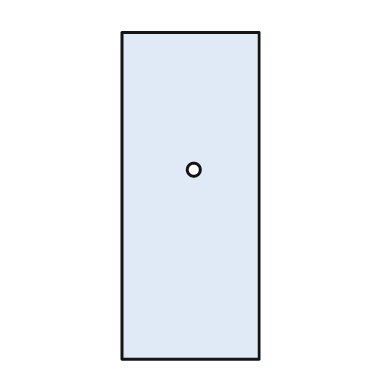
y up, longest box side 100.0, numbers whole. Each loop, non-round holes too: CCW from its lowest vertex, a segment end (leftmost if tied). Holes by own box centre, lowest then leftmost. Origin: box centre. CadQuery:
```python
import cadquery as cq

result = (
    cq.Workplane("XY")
    .moveTo(-21.0, -50.0)
    .lineTo(21.0, -50.0)
    .lineTo(21.0, 50.0)
    .lineTo(-21.0, 50.0)
    .close()
    .moveTo(1.0, 8.0)
    .circle(2.0)
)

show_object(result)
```